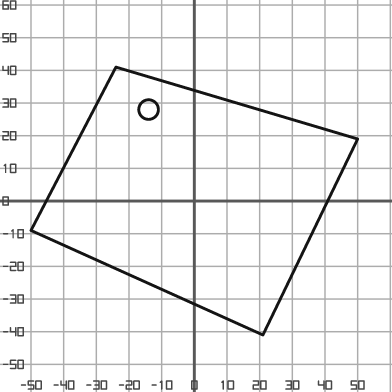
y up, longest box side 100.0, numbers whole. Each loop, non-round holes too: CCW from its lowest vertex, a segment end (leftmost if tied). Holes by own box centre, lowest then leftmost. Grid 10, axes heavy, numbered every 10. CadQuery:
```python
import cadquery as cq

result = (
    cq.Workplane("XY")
    .moveTo(21.0, -41.0)
    .lineTo(50.0, 19.0)
    .lineTo(-24.0, 41.0)
    .lineTo(-50.0, -9.0)
    .close()
    .moveTo(-14.0, 28.0)
    .circle(3.0)
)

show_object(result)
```